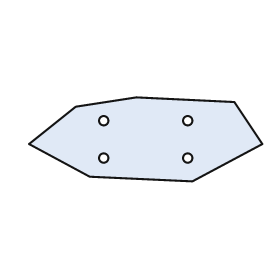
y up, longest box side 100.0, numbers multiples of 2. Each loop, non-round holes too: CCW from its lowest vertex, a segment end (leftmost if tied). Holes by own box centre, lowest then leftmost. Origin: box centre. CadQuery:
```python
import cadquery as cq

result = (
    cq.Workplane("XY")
    .moveTo(20.0, -18.0)
    .lineTo(50.0, -2.0)
    .lineTo(38.0, 16.0)
    .lineTo(-4.0, 18.0)
    .lineTo(-30.0, 14.0)
    .lineTo(-50.0, -2.0)
    .lineTo(-24.0, -16.0)
    .close()
    .moveTo(-18.0, -8.0)
    .circle(2.0)
    .moveTo(18.0, -8.0)
    .circle(2.0)
    .moveTo(-18.0, 8.0)
    .circle(2.0)
    .moveTo(18.0, 8.0)
    .circle(2.0)
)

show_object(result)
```